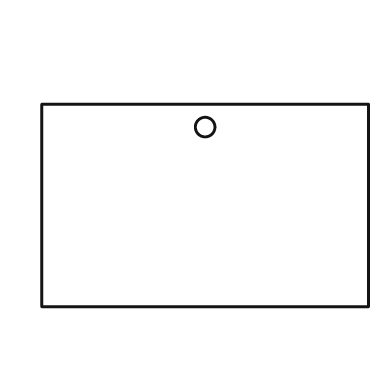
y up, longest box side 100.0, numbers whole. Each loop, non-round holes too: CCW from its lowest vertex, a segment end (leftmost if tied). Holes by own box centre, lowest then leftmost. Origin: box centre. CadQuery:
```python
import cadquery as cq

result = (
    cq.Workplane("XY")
    .moveTo(-50.0, -31.0)
    .lineTo(50.0, -31.0)
    .lineTo(50.0, 31.0)
    .lineTo(-50.0, 31.0)
    .close()
    .moveTo(0.0, 24.0)
    .circle(3.0)
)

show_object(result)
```